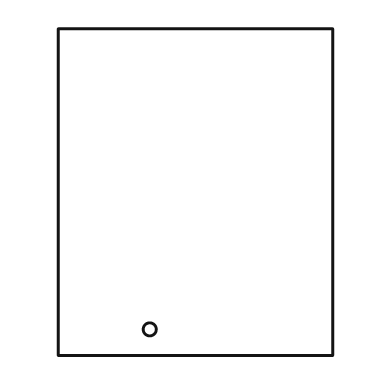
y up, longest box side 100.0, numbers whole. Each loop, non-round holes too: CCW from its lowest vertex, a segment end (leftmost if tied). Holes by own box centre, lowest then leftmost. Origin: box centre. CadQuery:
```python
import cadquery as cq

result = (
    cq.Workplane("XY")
    .moveTo(-42.0, -50.0)
    .lineTo(42.0, -50.0)
    .lineTo(42.0, 50.0)
    .lineTo(-42.0, 50.0)
    .close()
    .moveTo(-14.0, -42.0)
    .circle(2.0)
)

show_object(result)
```